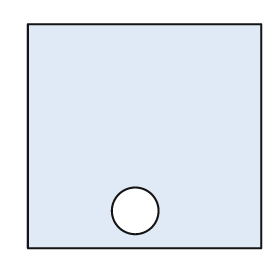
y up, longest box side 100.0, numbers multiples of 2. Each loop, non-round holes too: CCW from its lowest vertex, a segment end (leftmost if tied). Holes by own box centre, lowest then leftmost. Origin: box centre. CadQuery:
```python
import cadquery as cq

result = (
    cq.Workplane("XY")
    .moveTo(-50.0, -48.0)
    .lineTo(50.0, -48.0)
    .lineTo(50.0, 48.0)
    .lineTo(-50.0, 48.0)
    .close()
    .moveTo(-4.0, -32.0)
    .circle(10.0)
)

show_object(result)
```